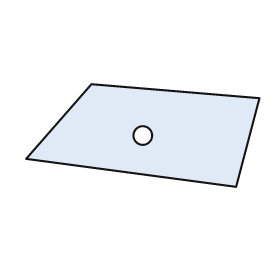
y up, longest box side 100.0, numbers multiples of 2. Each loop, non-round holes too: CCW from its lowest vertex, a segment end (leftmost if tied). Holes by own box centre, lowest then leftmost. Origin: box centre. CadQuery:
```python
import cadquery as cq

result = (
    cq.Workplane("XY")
    .moveTo(40.0, -22.0)
    .lineTo(50.0, 16.0)
    .lineTo(-22.0, 22.0)
    .lineTo(-50.0, -10.0)
    .close()
    .moveTo(0.0, 0.0)
    .circle(4.0)
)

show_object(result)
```